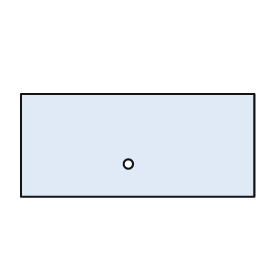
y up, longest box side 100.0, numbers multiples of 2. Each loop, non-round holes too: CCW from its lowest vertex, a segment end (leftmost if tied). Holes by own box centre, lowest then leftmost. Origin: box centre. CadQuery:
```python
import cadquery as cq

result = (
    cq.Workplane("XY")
    .moveTo(-50.0, -22.0)
    .lineTo(50.0, -22.0)
    .lineTo(50.0, 22.0)
    .lineTo(-50.0, 22.0)
    .close()
    .moveTo(-4.0, -8.0)
    .circle(2.0)
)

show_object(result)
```